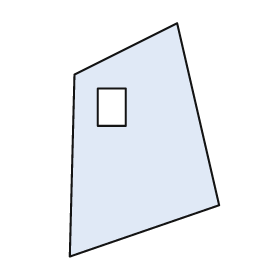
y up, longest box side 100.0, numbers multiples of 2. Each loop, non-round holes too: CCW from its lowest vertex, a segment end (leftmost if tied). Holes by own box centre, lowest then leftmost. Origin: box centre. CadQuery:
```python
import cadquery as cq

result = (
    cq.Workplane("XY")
    .moveTo(-32.0, -50.0)
    .lineTo(32.0, -28.0)
    .lineTo(14.0, 50.0)
    .lineTo(-30.0, 28.0)
    .close()
    .moveTo(-20.0, 6.0)
    .lineTo(-8.0, 6.0)
    .lineTo(-8.0, 22.0)
    .lineTo(-20.0, 22.0)
    .close()
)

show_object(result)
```